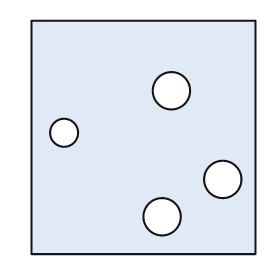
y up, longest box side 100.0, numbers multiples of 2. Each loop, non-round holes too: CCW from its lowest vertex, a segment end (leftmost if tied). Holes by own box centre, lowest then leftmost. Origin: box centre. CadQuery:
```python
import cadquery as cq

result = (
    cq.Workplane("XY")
    .moveTo(-48.0, -50.0)
    .lineTo(48.0, -50.0)
    .lineTo(48.0, 50.0)
    .lineTo(-48.0, 50.0)
    .close()
    .moveTo(8.0, -34.0)
    .circle(8.0)
    .moveTo(34.0, -18.0)
    .circle(8.0)
    .moveTo(-34.0, 2.0)
    .circle(6.0)
    .moveTo(12.0, 20.0)
    .circle(8.0)
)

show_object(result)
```